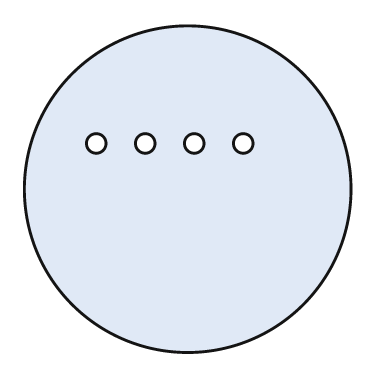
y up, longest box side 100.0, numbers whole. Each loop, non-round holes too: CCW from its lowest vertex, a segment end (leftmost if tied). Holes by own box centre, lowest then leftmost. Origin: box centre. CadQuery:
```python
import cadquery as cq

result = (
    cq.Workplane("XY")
    .moveTo(0.0, 0.0)
    .circle(50.0)
    .moveTo(-28.0, 14.0)
    .circle(3.0)
    .moveTo(-13.0, 14.0)
    .circle(3.0)
    .moveTo(2.0, 14.0)
    .circle(3.0)
    .moveTo(17.0, 14.0)
    .circle(3.0)
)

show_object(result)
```